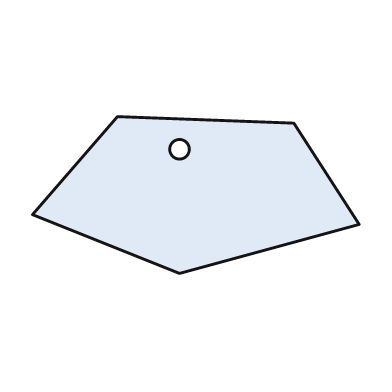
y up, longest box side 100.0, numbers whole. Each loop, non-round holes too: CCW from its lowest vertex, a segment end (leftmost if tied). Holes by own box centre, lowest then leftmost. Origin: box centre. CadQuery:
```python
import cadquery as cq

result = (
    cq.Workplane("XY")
    .moveTo(-5.0, -24.0)
    .lineTo(50.0, -9.0)
    .lineTo(30.0, 22.0)
    .lineTo(-24.0, 24.0)
    .lineTo(-50.0, -6.0)
    .close()
    .moveTo(-5.0, 14.0)
    .circle(3.0)
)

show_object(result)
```